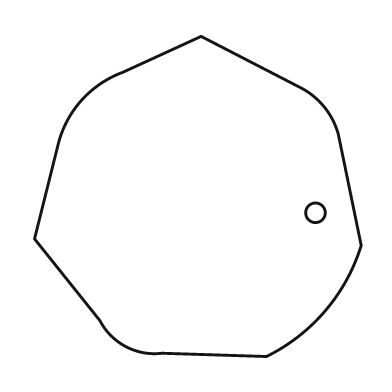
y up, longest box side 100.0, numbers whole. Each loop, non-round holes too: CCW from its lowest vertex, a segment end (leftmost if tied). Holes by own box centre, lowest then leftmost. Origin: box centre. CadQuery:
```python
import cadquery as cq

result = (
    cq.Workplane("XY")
    .moveTo(21.0, -49.0)
    .threePointArc((39.0, -35.0), (50.0, -15.0))
    .lineTo(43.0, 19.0)
    .threePointArc((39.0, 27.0), (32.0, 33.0))
    .lineTo(1.0, 49.0)
    .lineTo(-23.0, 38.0)
    .threePointArc((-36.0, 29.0), (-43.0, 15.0))
    .lineTo(-50.0, -13.0)
    .lineTo(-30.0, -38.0)
    .threePointArc((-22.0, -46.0), (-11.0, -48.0))
    .close()
    .moveTo(36.0, -5.0)
    .circle(3.0)
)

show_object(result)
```